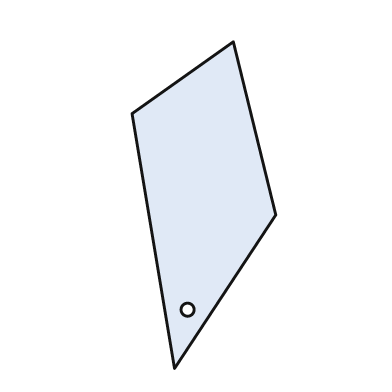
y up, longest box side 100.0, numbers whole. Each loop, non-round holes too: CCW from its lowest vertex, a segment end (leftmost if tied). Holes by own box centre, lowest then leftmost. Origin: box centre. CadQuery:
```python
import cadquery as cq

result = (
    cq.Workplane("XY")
    .moveTo(-9.0, -50.0)
    .lineTo(22.0, -3.0)
    .lineTo(9.0, 50.0)
    .lineTo(-22.0, 28.0)
    .close()
    .moveTo(-5.0, -32.0)
    .circle(2.0)
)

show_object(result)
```